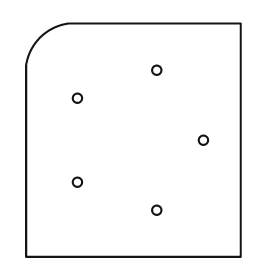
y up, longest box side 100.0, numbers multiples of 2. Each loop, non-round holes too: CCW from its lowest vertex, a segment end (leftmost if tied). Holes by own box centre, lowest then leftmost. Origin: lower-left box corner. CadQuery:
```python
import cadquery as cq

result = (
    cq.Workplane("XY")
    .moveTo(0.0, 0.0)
    .lineTo(92.0, 0.0)
    .lineTo(92.0, 100.0)
    .lineTo(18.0, 100.0)
    .threePointArc((6.0, 94.0), (0.0, 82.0))
    .close()
    .moveTo(56.0, 20.0)
    .circle(2.0)
    .moveTo(22.0, 32.0)
    .circle(2.0)
    .moveTo(76.0, 50.0)
    .circle(2.0)
    .moveTo(22.0, 68.0)
    .circle(2.0)
    .moveTo(56.0, 80.0)
    .circle(2.0)
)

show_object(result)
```